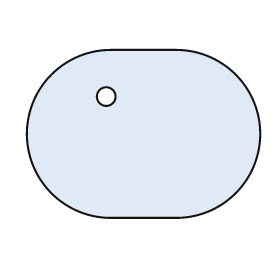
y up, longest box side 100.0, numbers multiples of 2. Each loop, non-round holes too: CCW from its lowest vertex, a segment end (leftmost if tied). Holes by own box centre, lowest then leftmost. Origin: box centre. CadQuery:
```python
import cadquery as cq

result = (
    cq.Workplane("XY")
    .moveTo(-14.0, -36.0)
    .lineTo(14.0, -36.0)
    .threePointArc((50.0, 0.0), (14.0, 36.0))
    .lineTo(-14.0, 36.0)
    .threePointArc((-50.0, 0.0), (-14.0, -36.0))
    .close()
    .moveTo(-16.0, 16.0)
    .circle(4.0)
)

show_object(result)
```